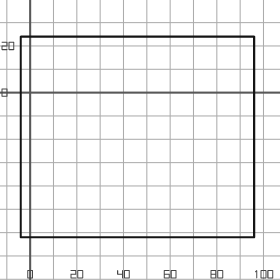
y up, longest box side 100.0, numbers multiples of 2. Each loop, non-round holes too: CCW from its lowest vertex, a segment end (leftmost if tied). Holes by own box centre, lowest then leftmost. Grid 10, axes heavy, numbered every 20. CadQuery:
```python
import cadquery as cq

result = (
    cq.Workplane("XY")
    .moveTo(-4.0, -62.0)
    .lineTo(96.0, -62.0)
    .lineTo(96.0, 24.0)
    .lineTo(-4.0, 24.0)
    .close()
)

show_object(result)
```